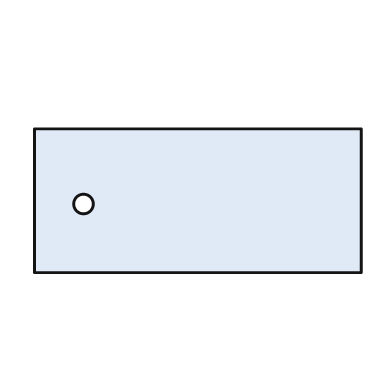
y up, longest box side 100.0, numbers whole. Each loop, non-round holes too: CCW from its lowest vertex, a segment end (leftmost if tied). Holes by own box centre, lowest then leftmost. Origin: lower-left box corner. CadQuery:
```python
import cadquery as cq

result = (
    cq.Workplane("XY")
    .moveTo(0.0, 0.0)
    .lineTo(100.0, 0.0)
    .lineTo(100.0, 44.0)
    .lineTo(0.0, 44.0)
    .close()
    .moveTo(15.0, 21.0)
    .circle(3.0)
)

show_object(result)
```